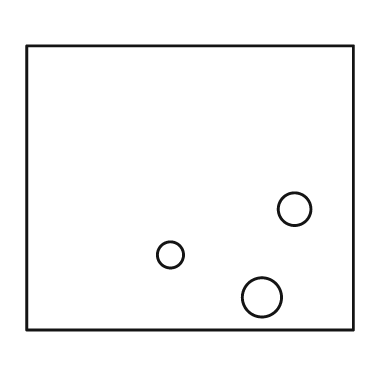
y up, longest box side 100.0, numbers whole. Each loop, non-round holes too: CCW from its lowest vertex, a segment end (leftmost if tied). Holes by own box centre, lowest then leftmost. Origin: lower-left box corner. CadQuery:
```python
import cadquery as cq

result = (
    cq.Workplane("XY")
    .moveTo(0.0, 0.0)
    .lineTo(100.0, 0.0)
    .lineTo(100.0, 87.0)
    .lineTo(0.0, 87.0)
    .close()
    .moveTo(72.0, 10.0)
    .circle(6.0)
    .moveTo(44.0, 23.0)
    .circle(4.0)
    .moveTo(82.0, 37.0)
    .circle(5.0)
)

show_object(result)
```